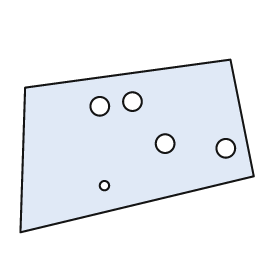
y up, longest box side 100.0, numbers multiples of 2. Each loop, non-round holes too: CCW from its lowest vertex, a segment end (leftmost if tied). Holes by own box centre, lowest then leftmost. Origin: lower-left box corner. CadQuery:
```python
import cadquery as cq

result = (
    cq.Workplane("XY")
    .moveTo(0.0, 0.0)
    .lineTo(100.0, 24.0)
    .lineTo(90.0, 74.0)
    .lineTo(2.0, 62.0)
    .close()
    .moveTo(36.0, 20.0)
    .circle(2.0)
    .moveTo(88.0, 36.0)
    .circle(4.0)
    .moveTo(62.0, 38.0)
    .circle(4.0)
    .moveTo(34.0, 54.0)
    .circle(4.0)
    .moveTo(48.0, 56.0)
    .circle(4.0)
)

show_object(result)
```